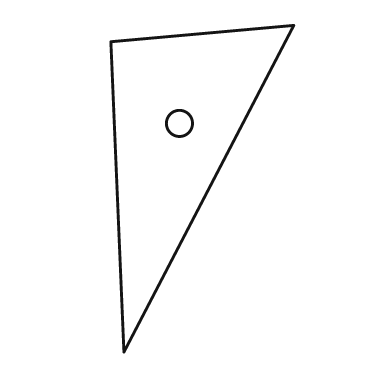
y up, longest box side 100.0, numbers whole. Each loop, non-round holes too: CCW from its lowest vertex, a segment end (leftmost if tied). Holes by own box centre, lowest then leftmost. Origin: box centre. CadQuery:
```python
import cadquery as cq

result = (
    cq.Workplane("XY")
    .moveTo(-24.0, -50.0)
    .lineTo(28.0, 50.0)
    .lineTo(-28.0, 45.0)
    .close()
    .moveTo(-7.0, 20.0)
    .circle(4.0)
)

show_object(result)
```